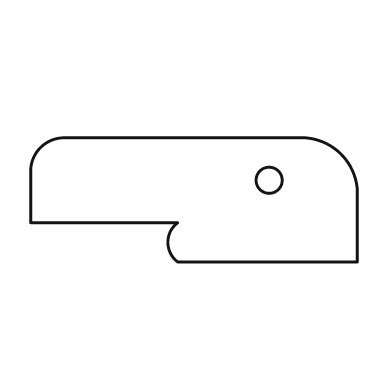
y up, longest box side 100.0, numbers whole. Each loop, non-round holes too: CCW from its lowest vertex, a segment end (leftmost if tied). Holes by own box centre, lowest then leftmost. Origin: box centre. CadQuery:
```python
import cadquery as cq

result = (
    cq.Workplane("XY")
    .moveTo(-5.0, -19.0)
    .lineTo(50.0, -19.0)
    .lineTo(50.0, 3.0)
    .threePointArc((45.0, 14.0), (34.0, 19.0))
    .lineTo(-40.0, 19.0)
    .threePointArc((-47.0, 16.0), (-50.0, 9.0))
    .lineTo(-50.0, -7.0)
    .lineTo(-5.0, -7.0)
    .threePointArc((-8.0, -13.0), (-5.0, -19.0))
    .close()
    .moveTo(23.0, 6.0)
    .circle(4.0)
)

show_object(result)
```